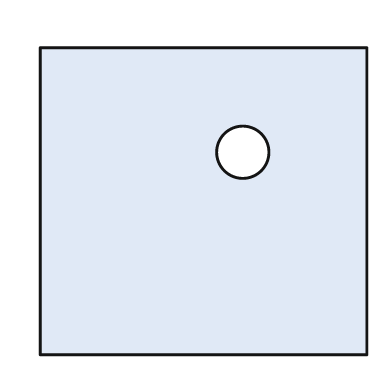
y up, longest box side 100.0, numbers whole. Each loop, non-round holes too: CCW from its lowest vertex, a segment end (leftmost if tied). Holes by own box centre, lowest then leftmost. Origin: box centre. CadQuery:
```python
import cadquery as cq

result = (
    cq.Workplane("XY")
    .moveTo(-50.0, -47.0)
    .lineTo(50.0, -47.0)
    .lineTo(50.0, 47.0)
    .lineTo(-50.0, 47.0)
    .close()
    .moveTo(12.0, 15.0)
    .circle(8.0)
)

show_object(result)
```